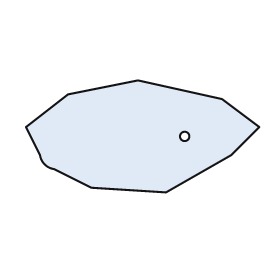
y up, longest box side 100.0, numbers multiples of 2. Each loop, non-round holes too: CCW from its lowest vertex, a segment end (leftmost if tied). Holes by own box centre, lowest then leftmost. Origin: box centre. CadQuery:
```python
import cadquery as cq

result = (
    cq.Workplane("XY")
    .moveTo(10.0, -24.0)
    .lineTo(38.0, -8.0)
    .lineTo(50.0, 4.0)
    .lineTo(34.0, 16.0)
    .lineTo(-2.0, 24.0)
    .lineTo(-32.0, 18.0)
    .lineTo(-50.0, 4.0)
    .lineTo(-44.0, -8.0)
    .threePointArc((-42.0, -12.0), (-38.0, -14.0))
    .lineTo(-22.0, -22.0)
    .close()
    .moveTo(18.0, 0.0)
    .circle(2.0)
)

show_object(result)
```